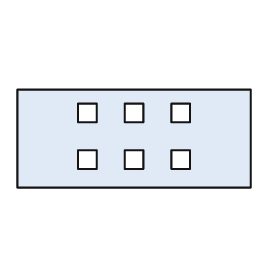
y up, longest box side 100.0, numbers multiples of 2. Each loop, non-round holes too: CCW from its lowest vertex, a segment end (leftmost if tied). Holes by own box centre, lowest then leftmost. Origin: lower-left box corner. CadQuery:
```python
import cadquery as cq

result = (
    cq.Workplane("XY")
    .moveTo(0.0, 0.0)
    .lineTo(100.0, 0.0)
    .lineTo(100.0, 42.0)
    .lineTo(0.0, 42.0)
    .close()
    .moveTo(26.0, 8.0)
    .lineTo(34.0, 8.0)
    .lineTo(34.0, 16.0)
    .lineTo(26.0, 16.0)
    .close()
    .moveTo(46.0, 8.0)
    .lineTo(54.0, 8.0)
    .lineTo(54.0, 16.0)
    .lineTo(46.0, 16.0)
    .close()
    .moveTo(66.0, 8.0)
    .lineTo(74.0, 8.0)
    .lineTo(74.0, 16.0)
    .lineTo(66.0, 16.0)
    .close()
    .moveTo(26.0, 28.0)
    .lineTo(34.0, 28.0)
    .lineTo(34.0, 36.0)
    .lineTo(26.0, 36.0)
    .close()
    .moveTo(46.0, 28.0)
    .lineTo(54.0, 28.0)
    .lineTo(54.0, 36.0)
    .lineTo(46.0, 36.0)
    .close()
    .moveTo(66.0, 28.0)
    .lineTo(74.0, 28.0)
    .lineTo(74.0, 36.0)
    .lineTo(66.0, 36.0)
    .close()
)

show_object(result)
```